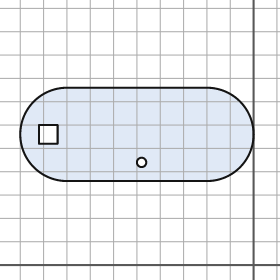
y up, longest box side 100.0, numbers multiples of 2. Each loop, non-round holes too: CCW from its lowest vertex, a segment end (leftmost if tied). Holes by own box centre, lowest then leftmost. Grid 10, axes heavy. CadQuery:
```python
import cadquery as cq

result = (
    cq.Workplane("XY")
    .moveTo(-80.0, 36.0)
    .lineTo(-20.0, 36.0)
    .threePointArc((0.0, 56.0), (-20.0, 76.0))
    .lineTo(-80.0, 76.0)
    .threePointArc((-100.0, 56.0), (-80.0, 36.0))
    .close()
    .moveTo(-48.0, 44.0)
    .circle(2.0)
    .moveTo(-92.0, 52.0)
    .lineTo(-84.0, 52.0)
    .lineTo(-84.0, 60.0)
    .lineTo(-92.0, 60.0)
    .close()
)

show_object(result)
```